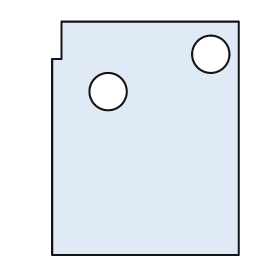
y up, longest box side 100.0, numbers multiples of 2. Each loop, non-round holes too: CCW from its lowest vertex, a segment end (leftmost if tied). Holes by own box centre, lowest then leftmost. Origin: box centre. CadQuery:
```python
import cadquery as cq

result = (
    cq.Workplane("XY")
    .moveTo(-40.0, -50.0)
    .lineTo(40.0, -50.0)
    .lineTo(40.0, 50.0)
    .lineTo(-36.0, 50.0)
    .lineTo(-36.0, 34.0)
    .lineTo(-40.0, 34.0)
    .close()
    .moveTo(-16.0, 20.0)
    .circle(8.0)
    .moveTo(28.0, 36.0)
    .circle(8.0)
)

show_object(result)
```